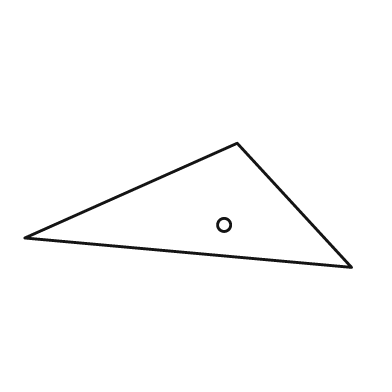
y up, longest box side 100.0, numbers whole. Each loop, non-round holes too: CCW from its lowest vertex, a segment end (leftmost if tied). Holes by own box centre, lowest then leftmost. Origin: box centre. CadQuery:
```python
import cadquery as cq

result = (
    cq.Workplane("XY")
    .moveTo(50.0, -19.0)
    .lineTo(15.0, 19.0)
    .lineTo(-50.0, -10.0)
    .close()
    .moveTo(11.0, -6.0)
    .circle(2.0)
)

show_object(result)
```